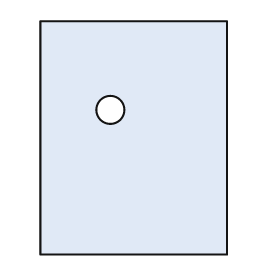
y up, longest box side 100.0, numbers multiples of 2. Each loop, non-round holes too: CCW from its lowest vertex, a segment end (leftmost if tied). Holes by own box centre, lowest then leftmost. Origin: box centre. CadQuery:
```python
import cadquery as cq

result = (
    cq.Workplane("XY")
    .moveTo(-40.0, -50.0)
    .lineTo(40.0, -50.0)
    .lineTo(40.0, 50.0)
    .lineTo(-40.0, 50.0)
    .close()
    .moveTo(-10.0, 12.0)
    .circle(6.0)
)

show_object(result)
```